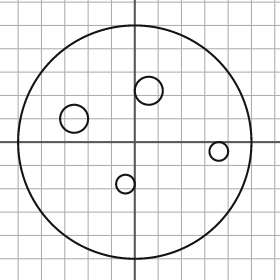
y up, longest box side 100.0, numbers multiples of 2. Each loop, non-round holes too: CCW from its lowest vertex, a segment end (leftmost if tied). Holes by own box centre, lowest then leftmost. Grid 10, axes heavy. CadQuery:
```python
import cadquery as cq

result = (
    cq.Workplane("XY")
    .moveTo(0.0, 0.0)
    .circle(50.0)
    .moveTo(-4.0, -18.0)
    .circle(4.0)
    .moveTo(36.0, -4.0)
    .circle(4.0)
    .moveTo(-26.0, 10.0)
    .circle(6.0)
    .moveTo(6.0, 22.0)
    .circle(6.0)
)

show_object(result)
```